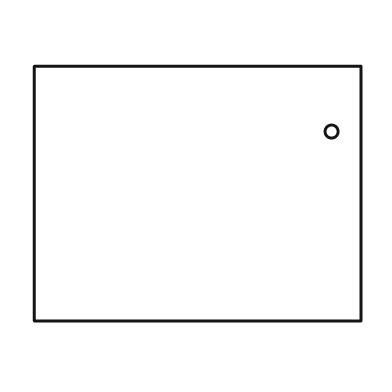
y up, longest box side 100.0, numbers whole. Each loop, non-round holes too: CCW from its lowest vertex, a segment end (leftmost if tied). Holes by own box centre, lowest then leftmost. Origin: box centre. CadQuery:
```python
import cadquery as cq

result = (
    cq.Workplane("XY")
    .moveTo(-50.0, -39.0)
    .lineTo(50.0, -39.0)
    .lineTo(50.0, 39.0)
    .lineTo(-50.0, 39.0)
    .close()
    .moveTo(41.0, 19.0)
    .circle(2.0)
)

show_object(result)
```